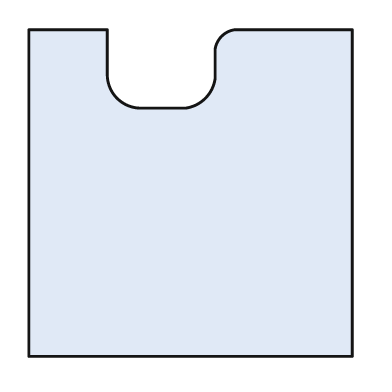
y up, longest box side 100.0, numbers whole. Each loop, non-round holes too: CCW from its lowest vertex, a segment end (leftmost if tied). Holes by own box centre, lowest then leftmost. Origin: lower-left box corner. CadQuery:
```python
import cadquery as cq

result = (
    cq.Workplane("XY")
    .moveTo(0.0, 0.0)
    .lineTo(99.0, 0.0)
    .lineTo(99.0, 100.0)
    .lineTo(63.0, 100.0)
    .threePointArc((59.0, 98.0), (57.0, 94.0))
    .lineTo(57.0, 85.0)
    .threePointArc((54.0, 79.0), (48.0, 76.0))
    .lineTo(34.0, 76.0)
    .threePointArc((27.0, 79.0), (24.0, 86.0))
    .lineTo(24.0, 100.0)
    .lineTo(0.0, 100.0)
    .close()
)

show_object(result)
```